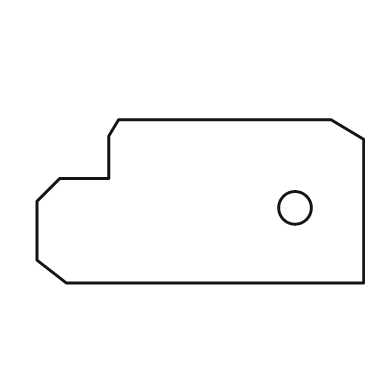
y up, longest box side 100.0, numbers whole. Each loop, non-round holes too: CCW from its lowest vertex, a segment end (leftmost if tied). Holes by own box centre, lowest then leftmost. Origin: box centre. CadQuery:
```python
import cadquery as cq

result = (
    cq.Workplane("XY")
    .moveTo(-41.0, -25.0)
    .lineTo(50.0, -25.0)
    .lineTo(50.0, 19.0)
    .lineTo(40.0, 25.0)
    .lineTo(-25.0, 25.0)
    .lineTo(-28.0, 20.0)
    .lineTo(-28.0, 7.0)
    .lineTo(-43.0, 7.0)
    .lineTo(-50.0, 0.0)
    .lineTo(-50.0, -18.0)
    .close()
    .moveTo(29.0, -2.0)
    .circle(5.0)
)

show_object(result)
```